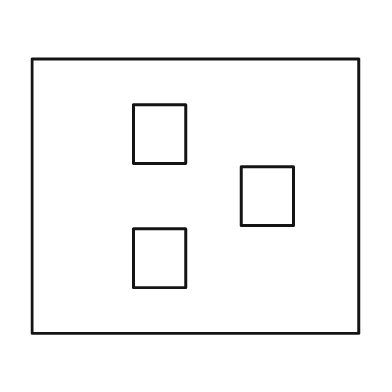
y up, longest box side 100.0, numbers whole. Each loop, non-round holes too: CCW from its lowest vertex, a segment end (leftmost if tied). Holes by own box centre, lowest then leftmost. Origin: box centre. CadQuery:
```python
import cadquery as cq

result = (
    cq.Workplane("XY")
    .moveTo(-50.0, -42.0)
    .lineTo(50.0, -42.0)
    .lineTo(50.0, 42.0)
    .lineTo(-50.0, 42.0)
    .close()
    .moveTo(-19.0, -28.0)
    .lineTo(-3.0, -28.0)
    .lineTo(-3.0, -10.0)
    .lineTo(-19.0, -10.0)
    .close()
    .moveTo(14.0, -9.0)
    .lineTo(30.0, -9.0)
    .lineTo(30.0, 9.0)
    .lineTo(14.0, 9.0)
    .close()
    .moveTo(-19.0, 10.0)
    .lineTo(-3.0, 10.0)
    .lineTo(-3.0, 28.0)
    .lineTo(-19.0, 28.0)
    .close()
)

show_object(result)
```